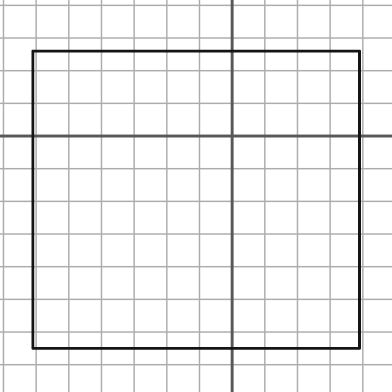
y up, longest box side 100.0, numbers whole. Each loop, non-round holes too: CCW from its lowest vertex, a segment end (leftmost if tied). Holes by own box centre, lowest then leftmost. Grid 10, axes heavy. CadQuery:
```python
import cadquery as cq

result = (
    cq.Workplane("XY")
    .moveTo(-61.0, -65.0)
    .lineTo(39.0, -65.0)
    .lineTo(39.0, 26.0)
    .lineTo(-61.0, 26.0)
    .close()
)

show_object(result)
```